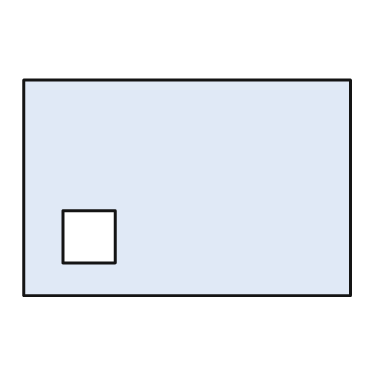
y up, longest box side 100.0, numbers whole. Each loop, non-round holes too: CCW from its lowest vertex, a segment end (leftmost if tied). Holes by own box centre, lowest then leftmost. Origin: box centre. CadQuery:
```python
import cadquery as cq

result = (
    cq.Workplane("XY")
    .moveTo(-50.0, -33.0)
    .lineTo(50.0, -33.0)
    .lineTo(50.0, 33.0)
    .lineTo(-50.0, 33.0)
    .close()
    .moveTo(-38.0, -23.0)
    .lineTo(-22.0, -23.0)
    .lineTo(-22.0, -7.0)
    .lineTo(-38.0, -7.0)
    .close()
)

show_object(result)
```